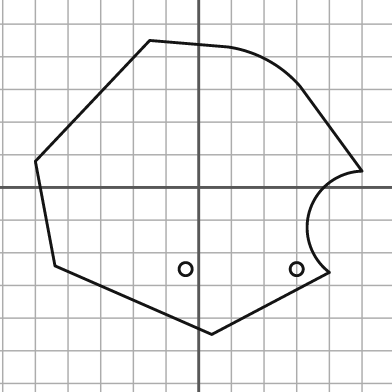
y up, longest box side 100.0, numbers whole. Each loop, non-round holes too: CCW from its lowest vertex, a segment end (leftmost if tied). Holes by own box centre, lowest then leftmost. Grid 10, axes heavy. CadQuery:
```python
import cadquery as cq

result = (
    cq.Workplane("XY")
    .moveTo(4.0, -45.0)
    .lineTo(40.0, -26.0)
    .threePointArc((34.0, -7.0), (50.0, 5.0))
    .lineTo(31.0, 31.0)
    .threePointArc((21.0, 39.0), (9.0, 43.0))
    .lineTo(-15.0, 45.0)
    .lineTo(-50.0, 8.0)
    .lineTo(-44.0, -24.0)
    .close()
    .moveTo(-4.0, -25.0)
    .circle(2.0)
    .moveTo(30.0, -25.0)
    .circle(2.0)
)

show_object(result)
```